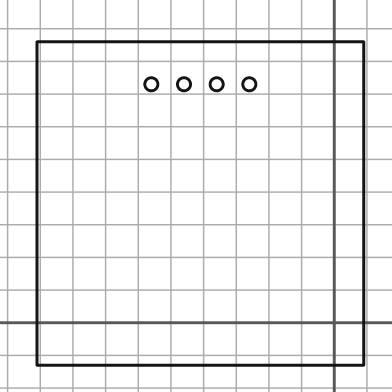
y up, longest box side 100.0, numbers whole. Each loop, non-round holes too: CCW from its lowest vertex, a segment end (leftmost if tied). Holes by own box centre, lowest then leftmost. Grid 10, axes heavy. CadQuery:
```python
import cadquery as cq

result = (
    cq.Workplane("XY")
    .moveTo(-91.0, -13.0)
    .lineTo(9.0, -13.0)
    .lineTo(9.0, 86.0)
    .lineTo(-91.0, 86.0)
    .close()
    .moveTo(-56.0, 73.0)
    .circle(2.0)
    .moveTo(-46.0, 73.0)
    .circle(2.0)
    .moveTo(-36.0, 73.0)
    .circle(2.0)
    .moveTo(-26.0, 73.0)
    .circle(2.0)
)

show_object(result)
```